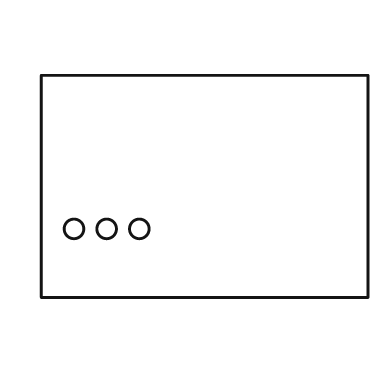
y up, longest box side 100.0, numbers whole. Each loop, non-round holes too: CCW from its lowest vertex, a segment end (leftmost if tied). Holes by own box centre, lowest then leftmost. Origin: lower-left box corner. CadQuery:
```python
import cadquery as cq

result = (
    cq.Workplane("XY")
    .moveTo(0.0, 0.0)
    .lineTo(100.0, 0.0)
    .lineTo(100.0, 68.0)
    .lineTo(0.0, 68.0)
    .close()
    .moveTo(10.0, 21.0)
    .circle(3.0)
    .moveTo(20.0, 21.0)
    .circle(3.0)
    .moveTo(30.0, 21.0)
    .circle(3.0)
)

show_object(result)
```